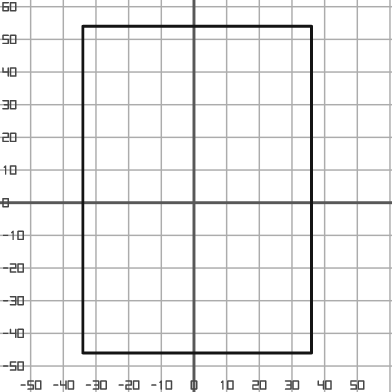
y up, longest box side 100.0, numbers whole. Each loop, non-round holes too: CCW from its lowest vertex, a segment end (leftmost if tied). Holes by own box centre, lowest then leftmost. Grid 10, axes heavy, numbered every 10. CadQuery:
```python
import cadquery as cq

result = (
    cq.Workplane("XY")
    .moveTo(-34.0, -46.0)
    .lineTo(36.0, -46.0)
    .lineTo(36.0, 54.0)
    .lineTo(-34.0, 54.0)
    .close()
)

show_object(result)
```